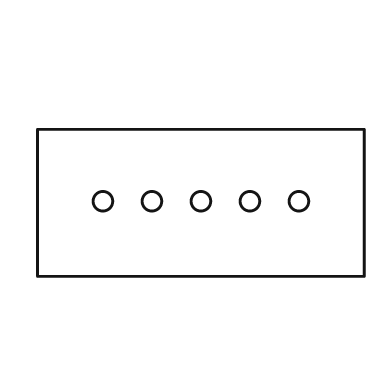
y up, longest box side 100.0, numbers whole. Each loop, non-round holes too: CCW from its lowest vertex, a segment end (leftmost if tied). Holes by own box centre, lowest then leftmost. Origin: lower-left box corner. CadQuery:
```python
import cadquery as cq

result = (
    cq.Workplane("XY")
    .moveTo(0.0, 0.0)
    .lineTo(100.0, 0.0)
    .lineTo(100.0, 45.0)
    .lineTo(0.0, 45.0)
    .close()
    .moveTo(20.0, 23.0)
    .circle(3.0)
    .moveTo(35.0, 23.0)
    .circle(3.0)
    .moveTo(50.0, 23.0)
    .circle(3.0)
    .moveTo(65.0, 23.0)
    .circle(3.0)
    .moveTo(80.0, 23.0)
    .circle(3.0)
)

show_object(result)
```